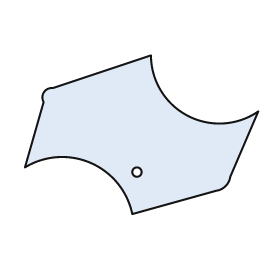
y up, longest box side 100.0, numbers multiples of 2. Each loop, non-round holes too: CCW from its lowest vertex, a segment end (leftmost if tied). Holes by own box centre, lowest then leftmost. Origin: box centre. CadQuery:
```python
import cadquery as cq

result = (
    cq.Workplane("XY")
    .moveTo(-4.0, -34.0)
    .lineTo(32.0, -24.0)
    .threePointArc((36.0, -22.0), (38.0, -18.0))
    .lineTo(50.0, 10.0)
    .threePointArc((20.0, 8.0), (4.0, 34.0))
    .lineTo(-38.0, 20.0)
    .threePointArc((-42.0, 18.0), (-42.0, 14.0))
    .lineTo(-50.0, -14.0)
    .threePointArc((-22.0, -12.0), (-4.0, -34.0))
    .close()
    .moveTo(-2.0, -16.0)
    .circle(2.0)
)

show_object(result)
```